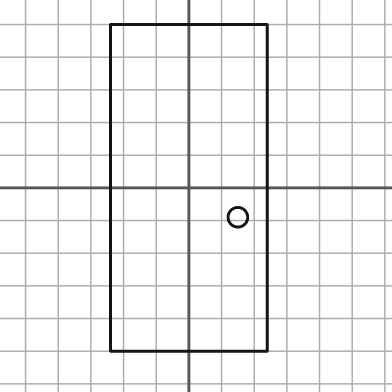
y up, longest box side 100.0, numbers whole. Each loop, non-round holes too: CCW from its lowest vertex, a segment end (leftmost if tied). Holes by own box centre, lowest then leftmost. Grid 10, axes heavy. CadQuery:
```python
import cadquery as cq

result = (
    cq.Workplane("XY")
    .moveTo(-24.0, -50.0)
    .lineTo(24.0, -50.0)
    .lineTo(24.0, 50.0)
    .lineTo(-24.0, 50.0)
    .close()
    .moveTo(15.0, -9.0)
    .circle(3.0)
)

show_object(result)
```